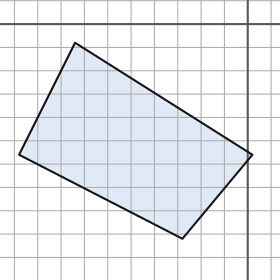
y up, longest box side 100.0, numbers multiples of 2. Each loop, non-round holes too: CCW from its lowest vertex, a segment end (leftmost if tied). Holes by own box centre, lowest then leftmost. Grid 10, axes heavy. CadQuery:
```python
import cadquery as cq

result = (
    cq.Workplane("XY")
    .moveTo(-28.0, -92.0)
    .lineTo(2.0, -56.0)
    .lineTo(-74.0, -8.0)
    .lineTo(-98.0, -56.0)
    .close()
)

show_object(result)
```